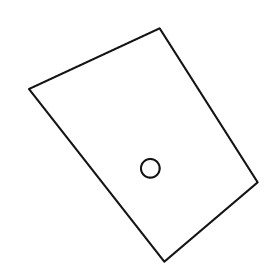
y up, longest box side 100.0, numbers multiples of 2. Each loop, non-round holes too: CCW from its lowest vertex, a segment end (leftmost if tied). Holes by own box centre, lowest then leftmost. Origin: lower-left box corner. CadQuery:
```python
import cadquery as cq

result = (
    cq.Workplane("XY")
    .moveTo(58.0, 0.0)
    .lineTo(98.0, 34.0)
    .lineTo(56.0, 100.0)
    .lineTo(0.0, 74.0)
    .close()
    .moveTo(52.0, 40.0)
    .circle(4.0)
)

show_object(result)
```